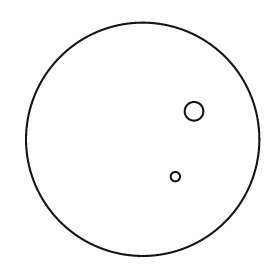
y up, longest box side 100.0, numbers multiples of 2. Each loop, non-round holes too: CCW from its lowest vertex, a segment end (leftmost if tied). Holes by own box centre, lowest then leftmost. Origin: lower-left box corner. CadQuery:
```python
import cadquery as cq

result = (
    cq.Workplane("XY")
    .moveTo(50.0, 50.0)
    .circle(50.0)
    .moveTo(64.0, 34.0)
    .circle(2.0)
    .moveTo(72.0, 62.0)
    .circle(4.0)
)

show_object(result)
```